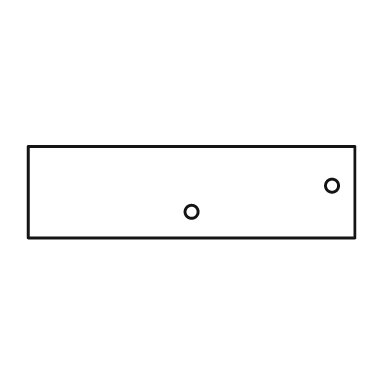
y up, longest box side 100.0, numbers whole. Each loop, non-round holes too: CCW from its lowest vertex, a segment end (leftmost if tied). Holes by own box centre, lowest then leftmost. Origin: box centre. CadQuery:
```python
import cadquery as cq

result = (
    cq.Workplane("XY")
    .moveTo(-50.0, -14.0)
    .lineTo(50.0, -14.0)
    .lineTo(50.0, 14.0)
    .lineTo(-50.0, 14.0)
    .close()
    .moveTo(0.0, -6.0)
    .circle(2.0)
    .moveTo(43.0, 2.0)
    .circle(2.0)
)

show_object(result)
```